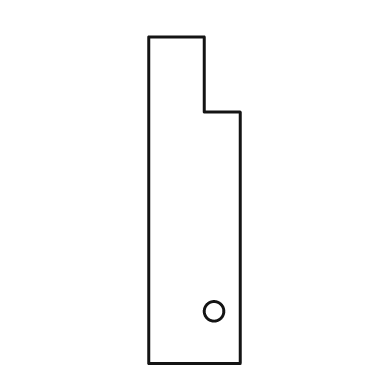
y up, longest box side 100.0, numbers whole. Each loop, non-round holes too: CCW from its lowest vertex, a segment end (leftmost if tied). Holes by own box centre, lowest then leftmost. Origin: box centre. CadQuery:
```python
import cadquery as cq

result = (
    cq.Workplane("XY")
    .moveTo(-14.0, -50.0)
    .lineTo(14.0, -50.0)
    .lineTo(14.0, 27.0)
    .lineTo(3.0, 27.0)
    .lineTo(3.0, 50.0)
    .lineTo(-14.0, 50.0)
    .close()
    .moveTo(6.0, -34.0)
    .circle(3.0)
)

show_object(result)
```